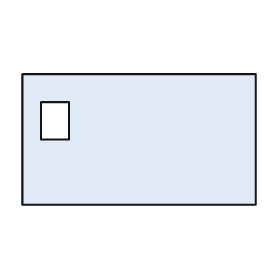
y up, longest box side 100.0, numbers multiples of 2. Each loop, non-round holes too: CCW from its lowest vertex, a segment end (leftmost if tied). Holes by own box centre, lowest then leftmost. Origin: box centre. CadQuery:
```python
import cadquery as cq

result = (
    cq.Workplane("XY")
    .moveTo(-50.0, -28.0)
    .lineTo(50.0, -28.0)
    .lineTo(50.0, 28.0)
    .lineTo(-50.0, 28.0)
    .close()
    .moveTo(-42.0, 0.0)
    .lineTo(-30.0, 0.0)
    .lineTo(-30.0, 16.0)
    .lineTo(-42.0, 16.0)
    .close()
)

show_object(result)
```